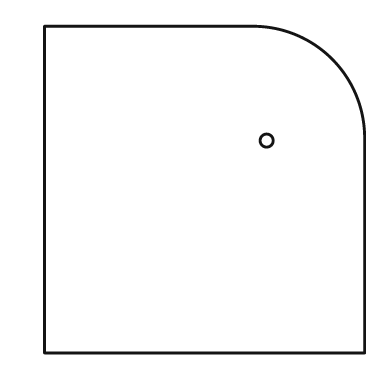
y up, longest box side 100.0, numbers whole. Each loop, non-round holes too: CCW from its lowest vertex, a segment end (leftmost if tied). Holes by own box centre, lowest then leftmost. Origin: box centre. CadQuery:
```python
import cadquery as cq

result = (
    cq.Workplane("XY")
    .moveTo(-49.0, -50.0)
    .lineTo(49.0, -50.0)
    .lineTo(49.0, 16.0)
    .threePointArc((39.0, 40.0), (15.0, 50.0))
    .lineTo(-49.0, 50.0)
    .close()
    .moveTo(19.0, 15.0)
    .circle(2.0)
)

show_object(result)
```